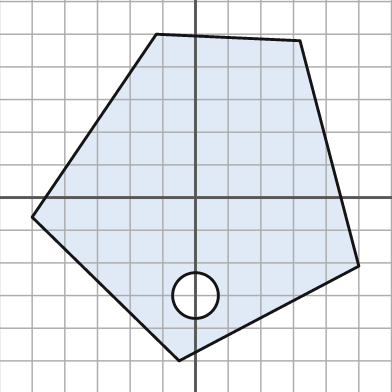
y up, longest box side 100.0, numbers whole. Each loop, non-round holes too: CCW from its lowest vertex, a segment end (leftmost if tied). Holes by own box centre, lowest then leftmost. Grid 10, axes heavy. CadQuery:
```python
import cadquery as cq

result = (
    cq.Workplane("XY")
    .moveTo(-5.0, -50.0)
    .lineTo(50.0, -21.0)
    .lineTo(32.0, 48.0)
    .lineTo(-12.0, 50.0)
    .lineTo(-50.0, -6.0)
    .close()
    .moveTo(0.0, -30.0)
    .circle(7.0)
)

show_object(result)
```